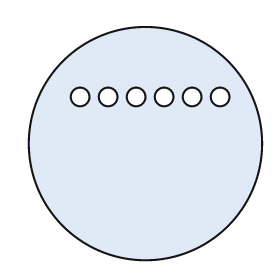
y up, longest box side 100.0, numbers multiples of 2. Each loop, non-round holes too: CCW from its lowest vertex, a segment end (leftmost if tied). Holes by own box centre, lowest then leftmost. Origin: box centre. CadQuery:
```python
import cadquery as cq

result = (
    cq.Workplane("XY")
    .moveTo(0.0, 0.0)
    .circle(50.0)
    .moveTo(-28.0, 20.0)
    .circle(4.0)
    .moveTo(-16.0, 20.0)
    .circle(4.0)
    .moveTo(-4.0, 20.0)
    .circle(4.0)
    .moveTo(8.0, 20.0)
    .circle(4.0)
    .moveTo(20.0, 20.0)
    .circle(4.0)
    .moveTo(32.0, 20.0)
    .circle(4.0)
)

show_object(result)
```